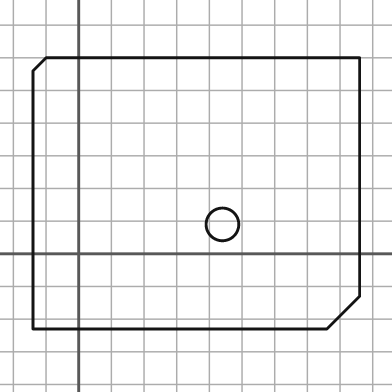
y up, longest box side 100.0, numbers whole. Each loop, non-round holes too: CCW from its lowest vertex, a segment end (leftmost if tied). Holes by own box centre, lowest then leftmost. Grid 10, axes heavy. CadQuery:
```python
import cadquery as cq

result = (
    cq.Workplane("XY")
    .moveTo(-14.0, -23.0)
    .lineTo(76.0, -23.0)
    .lineTo(86.0, -13.0)
    .lineTo(86.0, 60.0)
    .lineTo(-10.0, 60.0)
    .lineTo(-14.0, 56.0)
    .close()
    .moveTo(44.0, 9.0)
    .circle(5.0)
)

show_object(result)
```